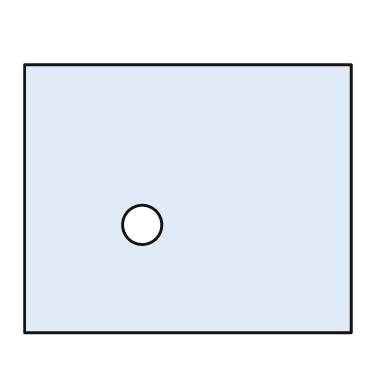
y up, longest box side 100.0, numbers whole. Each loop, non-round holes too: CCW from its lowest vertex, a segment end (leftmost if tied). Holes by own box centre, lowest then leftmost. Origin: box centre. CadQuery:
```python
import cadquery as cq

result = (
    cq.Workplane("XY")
    .moveTo(-50.0, -41.0)
    .lineTo(50.0, -41.0)
    .lineTo(50.0, 41.0)
    .lineTo(-50.0, 41.0)
    .close()
    .moveTo(-14.0, -8.0)
    .circle(6.0)
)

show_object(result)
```